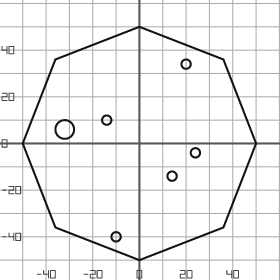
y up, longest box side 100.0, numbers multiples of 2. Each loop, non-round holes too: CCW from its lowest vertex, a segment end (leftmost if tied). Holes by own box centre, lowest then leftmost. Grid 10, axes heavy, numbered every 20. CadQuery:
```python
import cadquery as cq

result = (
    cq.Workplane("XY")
    .moveTo(0.0, -50.0)
    .lineTo(36.0, -36.0)
    .lineTo(50.0, 0.0)
    .lineTo(36.0, 36.0)
    .lineTo(0.0, 50.0)
    .lineTo(-36.0, 36.0)
    .lineTo(-50.0, 0.0)
    .lineTo(-36.0, -36.0)
    .close()
    .moveTo(-10.0, -40.0)
    .circle(2.0)
    .moveTo(14.0, -14.0)
    .circle(2.0)
    .moveTo(24.0, -4.0)
    .circle(2.0)
    .moveTo(-32.0, 6.0)
    .circle(4.0)
    .moveTo(-14.0, 10.0)
    .circle(2.0)
    .moveTo(20.0, 34.0)
    .circle(2.0)
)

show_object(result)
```